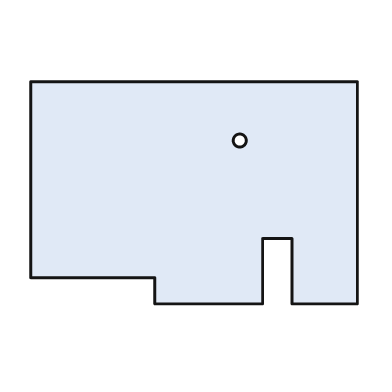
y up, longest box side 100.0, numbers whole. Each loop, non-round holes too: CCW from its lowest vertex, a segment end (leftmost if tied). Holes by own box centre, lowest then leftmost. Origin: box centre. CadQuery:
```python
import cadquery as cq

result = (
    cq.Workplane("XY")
    .moveTo(-12.0, -34.0)
    .lineTo(21.0, -34.0)
    .lineTo(21.0, -14.0)
    .lineTo(30.0, -14.0)
    .lineTo(30.0, -34.0)
    .lineTo(50.0, -34.0)
    .lineTo(50.0, 34.0)
    .lineTo(-50.0, 34.0)
    .lineTo(-50.0, -26.0)
    .lineTo(-12.0, -26.0)
    .close()
    .moveTo(14.0, 16.0)
    .circle(2.0)
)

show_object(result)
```